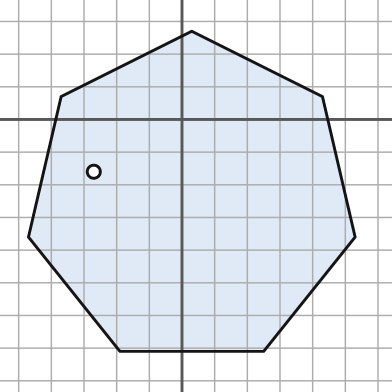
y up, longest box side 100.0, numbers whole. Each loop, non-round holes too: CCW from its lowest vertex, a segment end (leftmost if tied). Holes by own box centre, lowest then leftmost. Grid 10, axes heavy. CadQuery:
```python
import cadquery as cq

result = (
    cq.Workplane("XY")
    .moveTo(-19.0, -71.0)
    .lineTo(25.0, -71.0)
    .lineTo(53.0, -36.0)
    .lineTo(43.0, 7.0)
    .lineTo(3.0, 27.0)
    .lineTo(-37.0, 7.0)
    .lineTo(-47.0, -36.0)
    .close()
    .moveTo(-27.0, -16.0)
    .circle(2.0)
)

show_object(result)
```